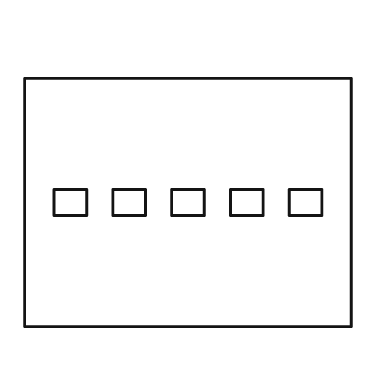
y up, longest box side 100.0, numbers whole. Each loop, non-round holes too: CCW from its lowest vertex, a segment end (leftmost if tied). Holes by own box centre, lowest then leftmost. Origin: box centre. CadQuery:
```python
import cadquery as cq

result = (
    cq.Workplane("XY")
    .moveTo(-50.0, -38.0)
    .lineTo(50.0, -38.0)
    .lineTo(50.0, 38.0)
    .lineTo(-50.0, 38.0)
    .close()
    .moveTo(-41.0, -4.0)
    .lineTo(-31.0, -4.0)
    .lineTo(-31.0, 4.0)
    .lineTo(-41.0, 4.0)
    .close()
    .moveTo(-23.0, -4.0)
    .lineTo(-13.0, -4.0)
    .lineTo(-13.0, 4.0)
    .lineTo(-23.0, 4.0)
    .close()
    .moveTo(-5.0, -4.0)
    .lineTo(5.0, -4.0)
    .lineTo(5.0, 4.0)
    .lineTo(-5.0, 4.0)
    .close()
    .moveTo(13.0, -4.0)
    .lineTo(23.0, -4.0)
    .lineTo(23.0, 4.0)
    .lineTo(13.0, 4.0)
    .close()
    .moveTo(31.0, -4.0)
    .lineTo(41.0, -4.0)
    .lineTo(41.0, 4.0)
    .lineTo(31.0, 4.0)
    .close()
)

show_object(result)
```